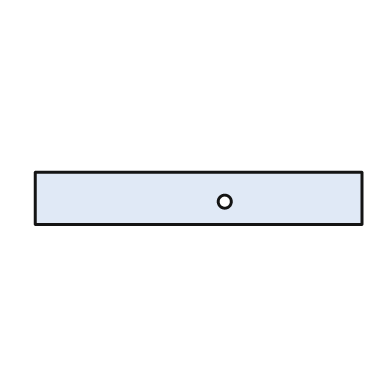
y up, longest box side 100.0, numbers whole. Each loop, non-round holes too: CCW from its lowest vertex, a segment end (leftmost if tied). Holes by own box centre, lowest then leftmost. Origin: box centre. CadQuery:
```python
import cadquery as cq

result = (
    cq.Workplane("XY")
    .moveTo(-50.0, -8.0)
    .lineTo(50.0, -8.0)
    .lineTo(50.0, 8.0)
    .lineTo(-50.0, 8.0)
    .close()
    .moveTo(8.0, -1.0)
    .circle(2.0)
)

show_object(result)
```